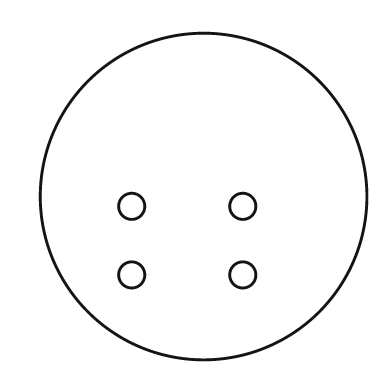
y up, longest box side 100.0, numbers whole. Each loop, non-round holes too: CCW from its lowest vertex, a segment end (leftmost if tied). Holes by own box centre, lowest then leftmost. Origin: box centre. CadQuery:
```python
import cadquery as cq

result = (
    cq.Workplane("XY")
    .moveTo(0.0, 0.0)
    .circle(50.0)
    .moveTo(-22.0, -24.0)
    .circle(4.0)
    .moveTo(12.0, -24.0)
    .circle(4.0)
    .moveTo(-22.0, -3.0)
    .circle(4.0)
    .moveTo(12.0, -3.0)
    .circle(4.0)
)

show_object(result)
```